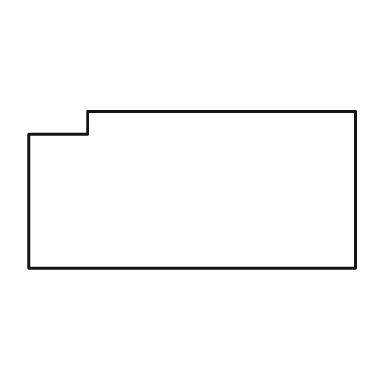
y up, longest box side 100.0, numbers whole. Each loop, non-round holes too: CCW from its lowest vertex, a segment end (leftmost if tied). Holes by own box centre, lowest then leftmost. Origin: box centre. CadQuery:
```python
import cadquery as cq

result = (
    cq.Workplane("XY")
    .moveTo(-50.0, -24.0)
    .lineTo(50.0, -24.0)
    .lineTo(50.0, 24.0)
    .lineTo(-32.0, 24.0)
    .lineTo(-32.0, 17.0)
    .lineTo(-50.0, 17.0)
    .close()
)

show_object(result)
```